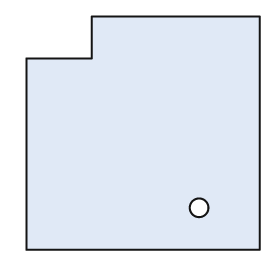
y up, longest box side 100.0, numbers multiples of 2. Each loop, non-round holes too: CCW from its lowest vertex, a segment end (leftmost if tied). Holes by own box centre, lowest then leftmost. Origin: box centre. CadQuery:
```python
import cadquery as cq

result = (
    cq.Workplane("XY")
    .moveTo(-50.0, -50.0)
    .lineTo(50.0, -50.0)
    .lineTo(50.0, 50.0)
    .lineTo(-22.0, 50.0)
    .lineTo(-22.0, 32.0)
    .lineTo(-50.0, 32.0)
    .close()
    .moveTo(24.0, -32.0)
    .circle(4.0)
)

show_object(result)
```